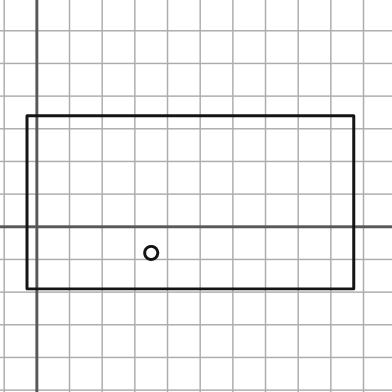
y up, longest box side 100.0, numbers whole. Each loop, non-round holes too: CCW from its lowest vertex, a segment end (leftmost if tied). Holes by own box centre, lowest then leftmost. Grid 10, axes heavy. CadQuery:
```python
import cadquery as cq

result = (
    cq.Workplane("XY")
    .moveTo(-3.0, -19.0)
    .lineTo(97.0, -19.0)
    .lineTo(97.0, 34.0)
    .lineTo(-3.0, 34.0)
    .close()
    .moveTo(35.0, -8.0)
    .circle(2.0)
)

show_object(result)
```